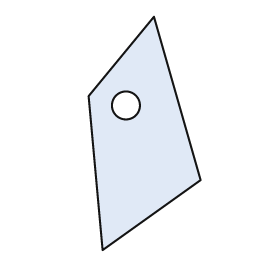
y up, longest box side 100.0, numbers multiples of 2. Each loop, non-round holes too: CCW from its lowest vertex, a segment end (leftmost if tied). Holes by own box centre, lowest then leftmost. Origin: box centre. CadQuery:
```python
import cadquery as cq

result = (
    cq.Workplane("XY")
    .moveTo(-18.0, -50.0)
    .lineTo(24.0, -20.0)
    .lineTo(4.0, 50.0)
    .lineTo(-24.0, 16.0)
    .close()
    .moveTo(-8.0, 12.0)
    .circle(6.0)
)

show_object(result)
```